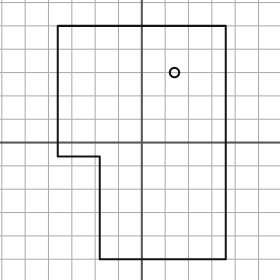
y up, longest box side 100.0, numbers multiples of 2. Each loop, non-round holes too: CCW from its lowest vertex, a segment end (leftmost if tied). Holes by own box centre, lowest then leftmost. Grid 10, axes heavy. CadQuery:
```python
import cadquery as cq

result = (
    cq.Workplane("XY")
    .moveTo(-18.0, -50.0)
    .lineTo(36.0, -50.0)
    .lineTo(36.0, 50.0)
    .lineTo(-36.0, 50.0)
    .lineTo(-36.0, -6.0)
    .lineTo(-18.0, -6.0)
    .close()
    .moveTo(14.0, 30.0)
    .circle(2.0)
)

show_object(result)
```